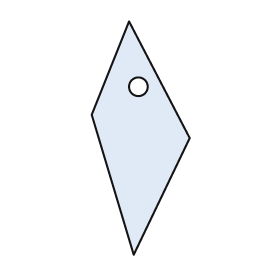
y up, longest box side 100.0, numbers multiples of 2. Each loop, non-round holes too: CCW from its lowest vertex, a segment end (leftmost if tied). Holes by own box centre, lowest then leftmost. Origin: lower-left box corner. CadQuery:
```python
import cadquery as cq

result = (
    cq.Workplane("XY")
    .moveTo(18.0, 0.0)
    .lineTo(42.0, 50.0)
    .lineTo(16.0, 100.0)
    .lineTo(0.0, 60.0)
    .close()
    .moveTo(20.0, 72.0)
    .circle(4.0)
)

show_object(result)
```